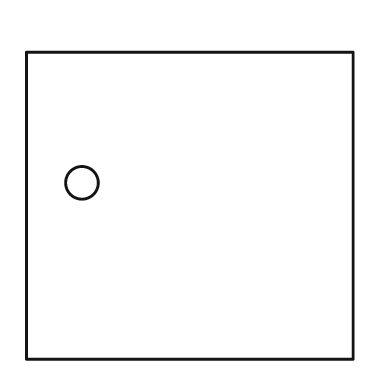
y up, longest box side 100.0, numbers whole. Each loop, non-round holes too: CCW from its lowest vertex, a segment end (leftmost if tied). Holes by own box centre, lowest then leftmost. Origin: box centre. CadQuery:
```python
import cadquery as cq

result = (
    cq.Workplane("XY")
    .moveTo(-50.0, -47.0)
    .lineTo(50.0, -47.0)
    .lineTo(50.0, 47.0)
    .lineTo(-50.0, 47.0)
    .close()
    .moveTo(-33.0, 7.0)
    .circle(5.0)
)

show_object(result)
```